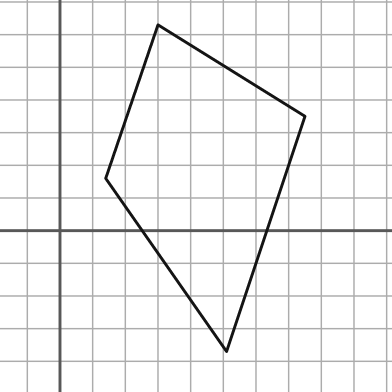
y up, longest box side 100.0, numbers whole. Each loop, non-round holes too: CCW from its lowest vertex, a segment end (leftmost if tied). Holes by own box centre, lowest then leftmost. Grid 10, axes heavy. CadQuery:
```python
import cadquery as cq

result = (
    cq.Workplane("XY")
    .moveTo(51.0, -37.0)
    .lineTo(75.0, 35.0)
    .lineTo(30.0, 63.0)
    .lineTo(14.0, 16.0)
    .close()
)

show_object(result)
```